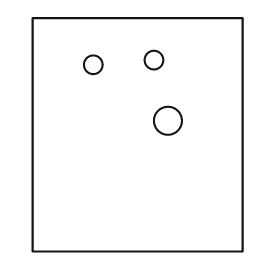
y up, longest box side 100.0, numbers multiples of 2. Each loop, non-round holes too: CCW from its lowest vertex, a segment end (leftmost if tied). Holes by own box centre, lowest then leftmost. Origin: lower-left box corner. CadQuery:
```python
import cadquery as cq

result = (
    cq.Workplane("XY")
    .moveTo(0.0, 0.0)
    .lineTo(90.0, 0.0)
    .lineTo(90.0, 100.0)
    .lineTo(0.0, 100.0)
    .close()
    .moveTo(58.0, 56.0)
    .circle(6.0)
    .moveTo(26.0, 80.0)
    .circle(4.0)
    .moveTo(52.0, 82.0)
    .circle(4.0)
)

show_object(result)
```